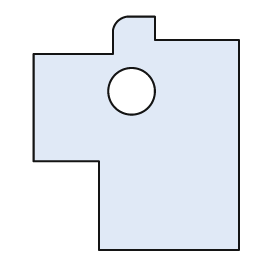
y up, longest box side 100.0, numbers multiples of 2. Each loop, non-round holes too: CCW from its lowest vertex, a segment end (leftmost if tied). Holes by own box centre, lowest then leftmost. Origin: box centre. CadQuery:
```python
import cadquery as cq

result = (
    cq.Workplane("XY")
    .moveTo(-16.0, -50.0)
    .lineTo(44.0, -50.0)
    .lineTo(44.0, 40.0)
    .lineTo(8.0, 40.0)
    .lineTo(8.0, 50.0)
    .lineTo(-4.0, 50.0)
    .threePointArc((-8.0, 48.0), (-10.0, 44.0))
    .lineTo(-10.0, 34.0)
    .lineTo(-44.0, 34.0)
    .lineTo(-44.0, -12.0)
    .lineTo(-16.0, -12.0)
    .close()
    .moveTo(-2.0, 18.0)
    .circle(10.0)
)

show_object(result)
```